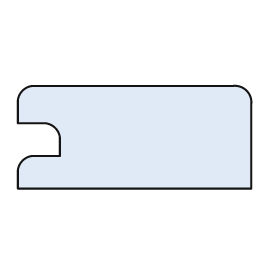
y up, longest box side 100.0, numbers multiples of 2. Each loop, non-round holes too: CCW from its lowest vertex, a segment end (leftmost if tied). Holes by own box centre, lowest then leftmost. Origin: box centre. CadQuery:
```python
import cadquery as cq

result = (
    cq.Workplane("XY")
    .moveTo(-50.0, -22.0)
    .lineTo(50.0, -22.0)
    .lineTo(50.0, 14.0)
    .threePointArc((48.0, 20.0), (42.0, 22.0))
    .lineTo(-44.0, 22.0)
    .threePointArc((-48.0, 20.0), (-50.0, 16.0))
    .lineTo(-50.0, 6.0)
    .lineTo(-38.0, 6.0)
    .threePointArc((-34.0, 4.0), (-32.0, 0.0))
    .lineTo(-32.0, -8.0)
    .lineTo(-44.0, -8.0)
    .threePointArc((-48.0, -10.0), (-50.0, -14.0))
    .close()
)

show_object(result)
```